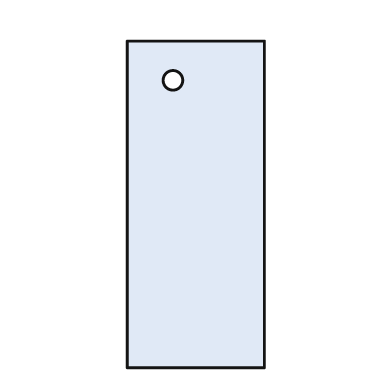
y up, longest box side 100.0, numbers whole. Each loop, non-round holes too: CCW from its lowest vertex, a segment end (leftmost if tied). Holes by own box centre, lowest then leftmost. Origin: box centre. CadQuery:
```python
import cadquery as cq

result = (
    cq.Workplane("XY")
    .moveTo(-21.0, -50.0)
    .lineTo(21.0, -50.0)
    .lineTo(21.0, 50.0)
    .lineTo(-21.0, 50.0)
    .close()
    .moveTo(-7.0, 38.0)
    .circle(3.0)
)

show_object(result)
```